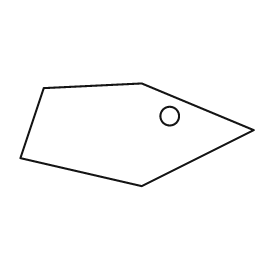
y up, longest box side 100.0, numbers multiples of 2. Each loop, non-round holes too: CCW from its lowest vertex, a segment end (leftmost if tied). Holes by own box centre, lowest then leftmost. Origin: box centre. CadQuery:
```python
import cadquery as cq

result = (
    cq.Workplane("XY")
    .moveTo(2.0, -22.0)
    .lineTo(50.0, 2.0)
    .lineTo(2.0, 22.0)
    .lineTo(-40.0, 20.0)
    .lineTo(-50.0, -10.0)
    .close()
    .moveTo(14.0, 8.0)
    .circle(4.0)
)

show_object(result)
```